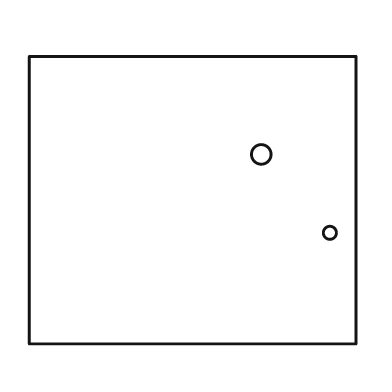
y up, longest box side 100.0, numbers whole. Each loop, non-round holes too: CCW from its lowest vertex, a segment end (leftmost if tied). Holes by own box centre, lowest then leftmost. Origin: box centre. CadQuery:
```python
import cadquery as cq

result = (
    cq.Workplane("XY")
    .moveTo(-50.0, -44.0)
    .lineTo(50.0, -44.0)
    .lineTo(50.0, 44.0)
    .lineTo(-50.0, 44.0)
    .close()
    .moveTo(42.0, -10.0)
    .circle(2.0)
    .moveTo(21.0, 14.0)
    .circle(3.0)
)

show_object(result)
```